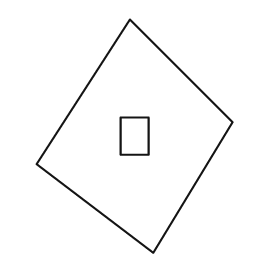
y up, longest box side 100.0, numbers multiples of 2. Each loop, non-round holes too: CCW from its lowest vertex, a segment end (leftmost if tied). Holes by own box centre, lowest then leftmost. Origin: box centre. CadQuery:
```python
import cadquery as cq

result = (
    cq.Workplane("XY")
    .moveTo(8.0, -50.0)
    .lineTo(42.0, 6.0)
    .lineTo(-2.0, 50.0)
    .lineTo(-42.0, -12.0)
    .close()
    .moveTo(-6.0, -8.0)
    .lineTo(6.0, -8.0)
    .lineTo(6.0, 8.0)
    .lineTo(-6.0, 8.0)
    .close()
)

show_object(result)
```